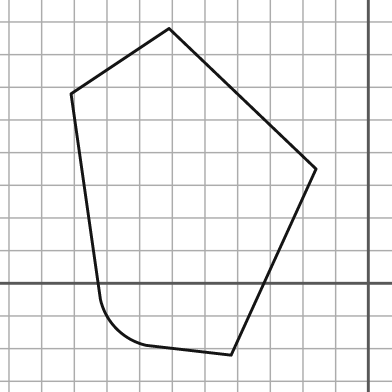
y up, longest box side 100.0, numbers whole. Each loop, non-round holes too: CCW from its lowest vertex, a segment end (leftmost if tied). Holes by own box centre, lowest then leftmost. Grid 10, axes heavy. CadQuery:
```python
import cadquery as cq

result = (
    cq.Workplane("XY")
    .moveTo(-42.0, -22.0)
    .lineTo(-16.0, 35.0)
    .lineTo(-61.0, 78.0)
    .lineTo(-91.0, 58.0)
    .lineTo(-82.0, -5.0)
    .threePointArc((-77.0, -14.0), (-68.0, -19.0))
    .close()
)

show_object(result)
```